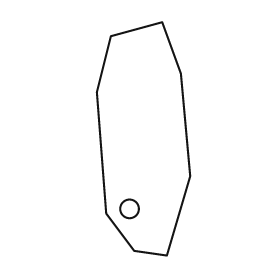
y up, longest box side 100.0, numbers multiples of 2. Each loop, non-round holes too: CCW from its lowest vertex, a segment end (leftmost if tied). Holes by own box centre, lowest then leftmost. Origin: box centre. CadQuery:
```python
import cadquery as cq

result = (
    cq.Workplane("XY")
    .moveTo(10.0, -50.0)
    .lineTo(20.0, -16.0)
    .lineTo(16.0, 28.0)
    .lineTo(8.0, 50.0)
    .lineTo(-14.0, 44.0)
    .lineTo(-20.0, 20.0)
    .lineTo(-16.0, -32.0)
    .lineTo(-4.0, -48.0)
    .close()
    .moveTo(-6.0, -30.0)
    .circle(4.0)
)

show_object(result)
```